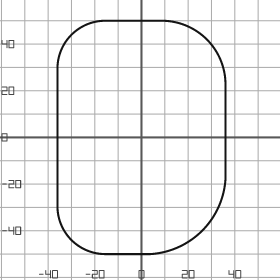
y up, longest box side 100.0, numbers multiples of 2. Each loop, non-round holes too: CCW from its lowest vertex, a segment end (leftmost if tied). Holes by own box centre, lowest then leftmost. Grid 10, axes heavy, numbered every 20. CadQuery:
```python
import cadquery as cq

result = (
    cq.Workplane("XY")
    .moveTo(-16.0, -50.0)
    .lineTo(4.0, -50.0)
    .threePointArc((26.0, -40.0), (36.0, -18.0))
    .lineTo(36.0, 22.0)
    .threePointArc((28.0, 42.0), (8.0, 50.0))
    .lineTo(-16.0, 50.0)
    .threePointArc((-30.0, 44.0), (-36.0, 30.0))
    .lineTo(-36.0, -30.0)
    .threePointArc((-30.0, -44.0), (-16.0, -50.0))
    .close()
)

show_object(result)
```